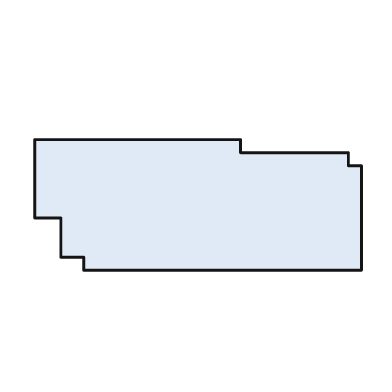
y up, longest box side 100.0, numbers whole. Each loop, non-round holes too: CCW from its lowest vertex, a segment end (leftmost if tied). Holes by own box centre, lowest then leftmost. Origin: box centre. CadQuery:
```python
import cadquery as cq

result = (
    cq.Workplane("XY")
    .moveTo(-35.0, -20.0)
    .lineTo(50.0, -20.0)
    .lineTo(50.0, 12.0)
    .lineTo(46.0, 12.0)
    .lineTo(46.0, 16.0)
    .lineTo(13.0, 16.0)
    .lineTo(13.0, 20.0)
    .lineTo(-50.0, 20.0)
    .lineTo(-50.0, -4.0)
    .lineTo(-42.0, -4.0)
    .lineTo(-42.0, -16.0)
    .lineTo(-35.0, -16.0)
    .close()
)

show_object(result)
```